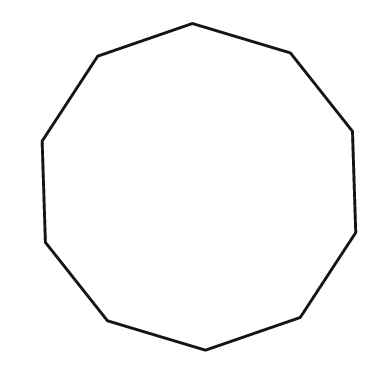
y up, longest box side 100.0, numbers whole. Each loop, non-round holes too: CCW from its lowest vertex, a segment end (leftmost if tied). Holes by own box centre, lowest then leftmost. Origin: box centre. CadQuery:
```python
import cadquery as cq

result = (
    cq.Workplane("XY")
    .moveTo(2.0, -50.0)
    .lineTo(31.0, -40.0)
    .lineTo(48.0, -14.0)
    .lineTo(47.0, 17.0)
    .lineTo(28.0, 41.0)
    .lineTo(-2.0, 50.0)
    .lineTo(-31.0, 40.0)
    .lineTo(-48.0, 14.0)
    .lineTo(-47.0, -17.0)
    .lineTo(-28.0, -41.0)
    .close()
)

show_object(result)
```